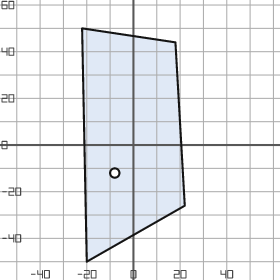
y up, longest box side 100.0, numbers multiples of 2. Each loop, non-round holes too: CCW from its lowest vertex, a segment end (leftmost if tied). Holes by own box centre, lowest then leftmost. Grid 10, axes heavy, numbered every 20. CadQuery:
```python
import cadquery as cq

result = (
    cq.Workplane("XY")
    .moveTo(-20.0, -50.0)
    .lineTo(22.0, -26.0)
    .lineTo(18.0, 44.0)
    .lineTo(-22.0, 50.0)
    .close()
    .moveTo(-8.0, -12.0)
    .circle(2.0)
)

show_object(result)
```